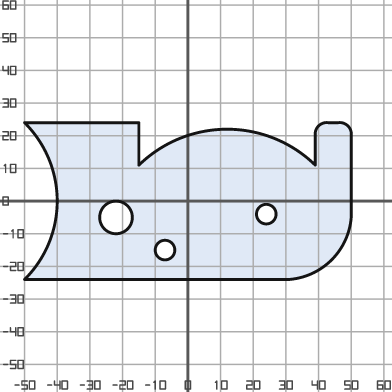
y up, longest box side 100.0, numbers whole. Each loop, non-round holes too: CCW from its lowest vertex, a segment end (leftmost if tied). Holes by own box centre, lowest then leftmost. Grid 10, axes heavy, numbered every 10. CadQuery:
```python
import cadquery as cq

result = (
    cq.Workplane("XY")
    .moveTo(-50.0, -24.0)
    .lineTo(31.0, -24.0)
    .threePointArc((44.0, -18.0), (50.0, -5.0))
    .lineTo(50.0, 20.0)
    .threePointArc((49.0, 23.0), (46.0, 24.0))
    .lineTo(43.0, 24.0)
    .threePointArc((40.0, 23.0), (39.0, 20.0))
    .lineTo(39.0, 11.0)
    .threePointArc((12.0, 22.0), (-15.0, 11.0))
    .lineTo(-15.0, 24.0)
    .lineTo(-50.0, 24.0)
    .threePointArc((-40.0, 0.0), (-50.0, -24.0))
    .close()
    .moveTo(-7.0, -15.0)
    .circle(3.0)
    .moveTo(-22.0, -5.0)
    .circle(5.0)
    .moveTo(24.0, -4.0)
    .circle(3.0)
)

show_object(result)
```